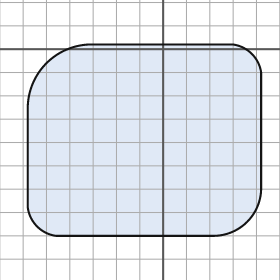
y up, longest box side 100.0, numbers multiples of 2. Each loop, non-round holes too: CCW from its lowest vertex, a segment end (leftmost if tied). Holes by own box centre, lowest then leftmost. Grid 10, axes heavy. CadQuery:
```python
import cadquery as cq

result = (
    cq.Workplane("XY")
    .moveTo(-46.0, -80.0)
    .lineTo(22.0, -80.0)
    .threePointArc((36.0, -74.0), (42.0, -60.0))
    .lineTo(42.0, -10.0)
    .threePointArc((38.0, -2.0), (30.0, 2.0))
    .lineTo(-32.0, 2.0)
    .threePointArc((-50.0, -6.0), (-58.0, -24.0))
    .lineTo(-58.0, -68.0)
    .threePointArc((-54.0, -76.0), (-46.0, -80.0))
    .close()
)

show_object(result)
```